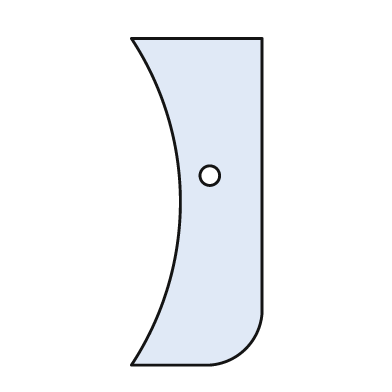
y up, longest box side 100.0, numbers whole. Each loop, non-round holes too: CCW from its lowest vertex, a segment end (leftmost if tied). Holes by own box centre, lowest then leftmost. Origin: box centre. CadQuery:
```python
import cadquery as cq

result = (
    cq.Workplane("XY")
    .moveTo(-20.0, -50.0)
    .lineTo(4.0, -50.0)
    .threePointArc((15.0, -45.0), (20.0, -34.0))
    .lineTo(20.0, 50.0)
    .lineTo(-20.0, 50.0)
    .threePointArc((-5.0, 0.0), (-20.0, -50.0))
    .close()
    .moveTo(4.0, 8.0)
    .circle(3.0)
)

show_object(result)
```